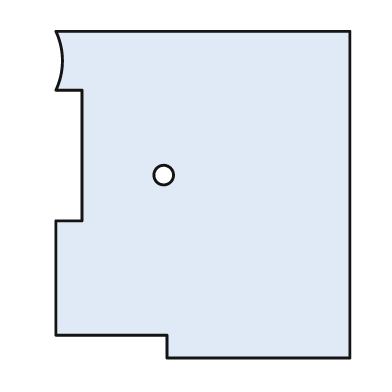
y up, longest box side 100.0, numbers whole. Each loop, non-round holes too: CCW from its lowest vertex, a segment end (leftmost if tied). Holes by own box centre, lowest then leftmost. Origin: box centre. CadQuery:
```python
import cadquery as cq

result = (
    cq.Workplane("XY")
    .moveTo(-11.0, -50.0)
    .lineTo(45.0, -50.0)
    .lineTo(45.0, 50.0)
    .lineTo(-45.0, 50.0)
    .threePointArc((-43.0, 41.0), (-45.0, 32.0))
    .lineTo(-37.0, 32.0)
    .lineTo(-37.0, -8.0)
    .lineTo(-45.0, -8.0)
    .lineTo(-45.0, -43.0)
    .lineTo(-11.0, -43.0)
    .close()
    .moveTo(-12.0, 6.0)
    .circle(3.0)
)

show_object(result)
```